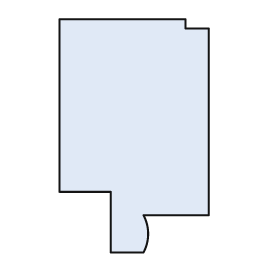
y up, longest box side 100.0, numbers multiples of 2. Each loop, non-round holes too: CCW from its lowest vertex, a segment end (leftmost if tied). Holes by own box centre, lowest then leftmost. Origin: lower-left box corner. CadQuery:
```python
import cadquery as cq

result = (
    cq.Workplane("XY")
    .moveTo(22.0, 0.0)
    .lineTo(36.0, 0.0)
    .threePointArc((38.0, 8.0), (36.0, 16.0))
    .lineTo(64.0, 16.0)
    .lineTo(64.0, 96.0)
    .lineTo(54.0, 96.0)
    .lineTo(54.0, 100.0)
    .lineTo(0.0, 100.0)
    .lineTo(0.0, 26.0)
    .lineTo(22.0, 26.0)
    .close()
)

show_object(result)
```